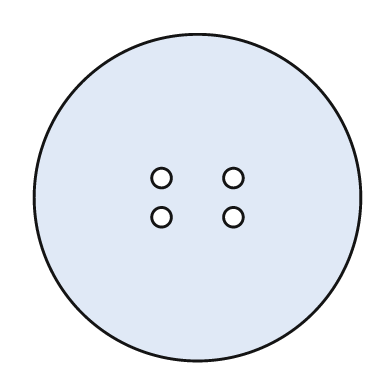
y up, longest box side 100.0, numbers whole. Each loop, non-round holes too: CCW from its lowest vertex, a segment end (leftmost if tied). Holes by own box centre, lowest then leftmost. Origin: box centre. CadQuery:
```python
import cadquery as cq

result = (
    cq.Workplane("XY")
    .moveTo(0.0, 0.0)
    .circle(50.0)
    .moveTo(-11.0, -6.0)
    .circle(3.0)
    .moveTo(11.0, -6.0)
    .circle(3.0)
    .moveTo(-11.0, 6.0)
    .circle(3.0)
    .moveTo(11.0, 6.0)
    .circle(3.0)
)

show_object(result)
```